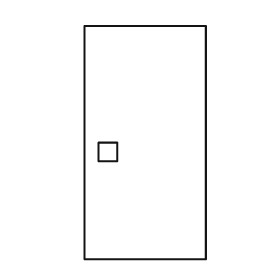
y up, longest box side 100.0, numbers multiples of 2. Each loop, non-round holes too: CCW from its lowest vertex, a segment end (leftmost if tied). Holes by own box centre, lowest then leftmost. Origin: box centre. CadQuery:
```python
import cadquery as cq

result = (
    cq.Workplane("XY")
    .moveTo(-26.0, -50.0)
    .lineTo(26.0, -50.0)
    .lineTo(26.0, 50.0)
    .lineTo(-26.0, 50.0)
    .close()
    .moveTo(-20.0, -8.0)
    .lineTo(-12.0, -8.0)
    .lineTo(-12.0, 0.0)
    .lineTo(-20.0, 0.0)
    .close()
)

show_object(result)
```